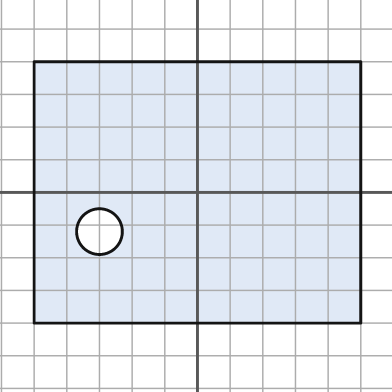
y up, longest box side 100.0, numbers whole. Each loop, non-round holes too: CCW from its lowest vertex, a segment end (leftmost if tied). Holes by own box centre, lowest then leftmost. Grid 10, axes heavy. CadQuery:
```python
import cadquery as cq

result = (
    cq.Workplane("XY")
    .moveTo(-50.0, -40.0)
    .lineTo(50.0, -40.0)
    .lineTo(50.0, 40.0)
    .lineTo(-50.0, 40.0)
    .close()
    .moveTo(-30.0, -12.0)
    .circle(7.0)
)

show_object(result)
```